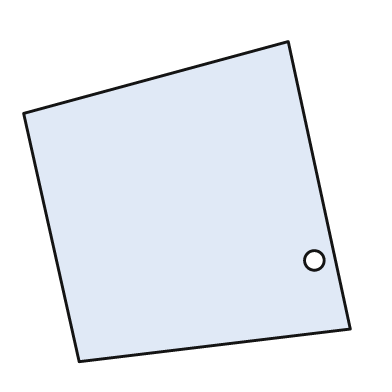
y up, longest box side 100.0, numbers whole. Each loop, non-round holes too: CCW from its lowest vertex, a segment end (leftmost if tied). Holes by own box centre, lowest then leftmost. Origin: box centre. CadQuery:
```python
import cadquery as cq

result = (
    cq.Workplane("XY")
    .moveTo(-33.0, -49.0)
    .lineTo(50.0, -39.0)
    .lineTo(31.0, 49.0)
    .lineTo(-50.0, 27.0)
    .close()
    .moveTo(39.0, -18.0)
    .circle(3.0)
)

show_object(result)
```